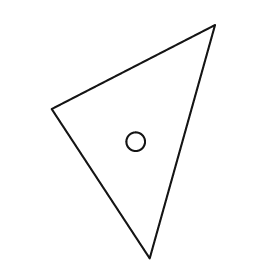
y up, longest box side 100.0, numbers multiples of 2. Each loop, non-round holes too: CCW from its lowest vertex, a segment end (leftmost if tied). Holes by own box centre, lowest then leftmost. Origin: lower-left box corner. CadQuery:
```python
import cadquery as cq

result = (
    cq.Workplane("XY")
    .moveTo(42.0, 0.0)
    .lineTo(70.0, 100.0)
    .lineTo(0.0, 64.0)
    .close()
    .moveTo(36.0, 50.0)
    .circle(4.0)
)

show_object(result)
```